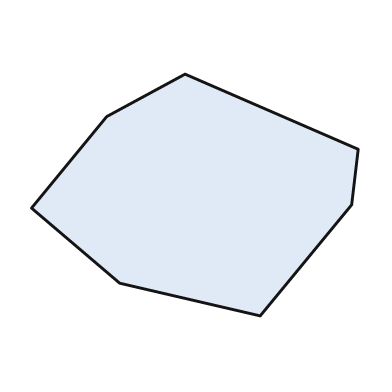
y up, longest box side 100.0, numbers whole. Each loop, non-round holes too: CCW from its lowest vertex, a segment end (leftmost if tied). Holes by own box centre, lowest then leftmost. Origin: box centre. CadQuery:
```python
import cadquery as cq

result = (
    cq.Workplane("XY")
    .moveTo(20.0, -37.0)
    .lineTo(48.0, -3.0)
    .lineTo(50.0, 14.0)
    .lineTo(-3.0, 37.0)
    .lineTo(-27.0, 24.0)
    .lineTo(-50.0, -4.0)
    .lineTo(-23.0, -27.0)
    .close()
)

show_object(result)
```